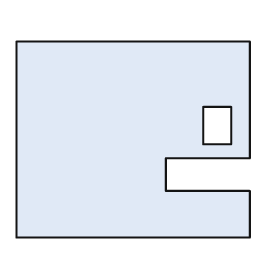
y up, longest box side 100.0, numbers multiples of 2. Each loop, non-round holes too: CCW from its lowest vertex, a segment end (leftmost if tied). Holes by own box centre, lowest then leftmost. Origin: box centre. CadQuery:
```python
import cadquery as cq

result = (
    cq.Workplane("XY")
    .moveTo(-50.0, -42.0)
    .lineTo(50.0, -42.0)
    .lineTo(50.0, -22.0)
    .lineTo(14.0, -22.0)
    .lineTo(14.0, -8.0)
    .lineTo(50.0, -8.0)
    .lineTo(50.0, 42.0)
    .lineTo(-50.0, 42.0)
    .close()
    .moveTo(30.0, -2.0)
    .lineTo(42.0, -2.0)
    .lineTo(42.0, 14.0)
    .lineTo(30.0, 14.0)
    .close()
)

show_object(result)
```